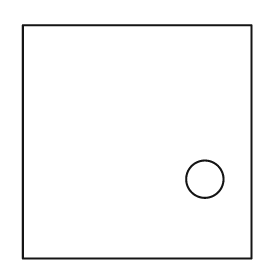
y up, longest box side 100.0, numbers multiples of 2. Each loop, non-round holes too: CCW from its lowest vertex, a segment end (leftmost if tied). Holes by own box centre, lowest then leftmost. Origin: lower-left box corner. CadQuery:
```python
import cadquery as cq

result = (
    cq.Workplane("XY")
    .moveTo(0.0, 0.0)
    .lineTo(98.0, 0.0)
    .lineTo(98.0, 100.0)
    .lineTo(0.0, 100.0)
    .close()
    .moveTo(78.0, 34.0)
    .circle(8.0)
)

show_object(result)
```